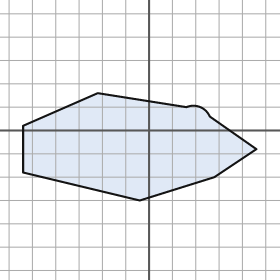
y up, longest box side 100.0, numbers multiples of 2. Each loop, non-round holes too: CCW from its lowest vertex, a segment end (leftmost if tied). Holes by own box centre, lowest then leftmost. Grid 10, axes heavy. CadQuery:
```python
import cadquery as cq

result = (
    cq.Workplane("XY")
    .moveTo(-4.0, -30.0)
    .lineTo(28.0, -20.0)
    .lineTo(46.0, -8.0)
    .lineTo(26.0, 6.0)
    .threePointArc((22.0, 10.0), (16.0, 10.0))
    .lineTo(-22.0, 16.0)
    .lineTo(-54.0, 2.0)
    .lineTo(-54.0, -18.0)
    .close()
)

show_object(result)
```